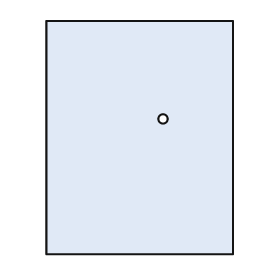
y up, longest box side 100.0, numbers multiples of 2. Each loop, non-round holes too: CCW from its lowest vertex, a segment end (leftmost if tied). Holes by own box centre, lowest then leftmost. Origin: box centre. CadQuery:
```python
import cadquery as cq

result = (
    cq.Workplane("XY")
    .moveTo(-40.0, -50.0)
    .lineTo(40.0, -50.0)
    .lineTo(40.0, 50.0)
    .lineTo(-40.0, 50.0)
    .close()
    .moveTo(10.0, 8.0)
    .circle(2.0)
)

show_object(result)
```